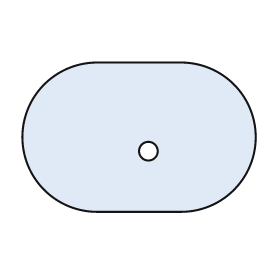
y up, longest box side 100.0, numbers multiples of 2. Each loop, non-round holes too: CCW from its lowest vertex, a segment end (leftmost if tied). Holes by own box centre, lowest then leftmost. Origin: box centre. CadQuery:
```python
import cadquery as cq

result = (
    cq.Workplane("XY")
    .moveTo(-18.0, -32.0)
    .lineTo(18.0, -32.0)
    .threePointArc((50.0, 0.0), (18.0, 32.0))
    .lineTo(-18.0, 32.0)
    .threePointArc((-50.0, 0.0), (-18.0, -32.0))
    .close()
    .moveTo(4.0, -6.0)
    .circle(4.0)
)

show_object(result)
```